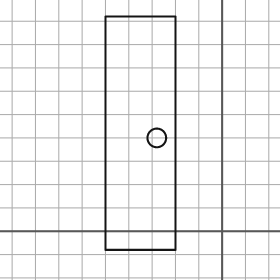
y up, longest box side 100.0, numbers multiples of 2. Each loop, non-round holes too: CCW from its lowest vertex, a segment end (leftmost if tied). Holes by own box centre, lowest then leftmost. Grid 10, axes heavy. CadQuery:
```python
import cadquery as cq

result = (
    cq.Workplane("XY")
    .moveTo(-50.0, -8.0)
    .lineTo(-20.0, -8.0)
    .lineTo(-20.0, 92.0)
    .lineTo(-50.0, 92.0)
    .close()
    .moveTo(-28.0, 40.0)
    .circle(4.0)
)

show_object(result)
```